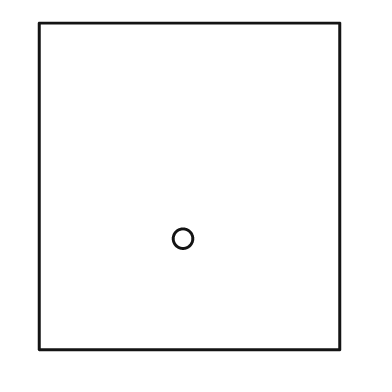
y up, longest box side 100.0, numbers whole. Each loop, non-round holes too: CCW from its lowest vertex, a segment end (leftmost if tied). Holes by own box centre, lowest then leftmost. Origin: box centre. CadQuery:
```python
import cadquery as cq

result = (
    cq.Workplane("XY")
    .moveTo(-46.0, -50.0)
    .lineTo(46.0, -50.0)
    .lineTo(46.0, 50.0)
    .lineTo(-46.0, 50.0)
    .close()
    .moveTo(-2.0, -16.0)
    .circle(3.0)
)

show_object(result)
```